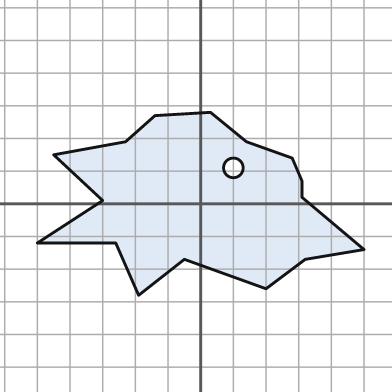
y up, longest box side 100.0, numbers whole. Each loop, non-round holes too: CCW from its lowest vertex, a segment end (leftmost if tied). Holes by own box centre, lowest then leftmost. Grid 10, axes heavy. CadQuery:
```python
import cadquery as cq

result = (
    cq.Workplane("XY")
    .moveTo(-19.0, -28.0)
    .lineTo(-5.0, -17.0)
    .lineTo(20.0, -26.0)
    .lineTo(32.0, -17.0)
    .lineTo(50.0, -14.0)
    .lineTo(31.0, 2.0)
    .lineTo(31.0, 7.0)
    .lineTo(28.0, 14.0)
    .lineTo(14.0, 19.0)
    .lineTo(3.0, 28.0)
    .lineTo(-14.0, 27.0)
    .lineTo(-23.0, 19.0)
    .lineTo(-45.0, 15.0)
    .lineTo(-30.0, 1.0)
    .lineTo(-50.0, -12.0)
    .lineTo(-26.0, -12.0)
    .close()
    .moveTo(10.0, 11.0)
    .circle(3.0)
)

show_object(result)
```